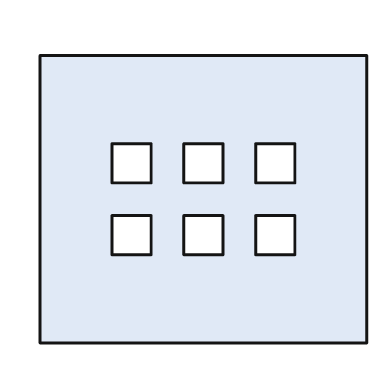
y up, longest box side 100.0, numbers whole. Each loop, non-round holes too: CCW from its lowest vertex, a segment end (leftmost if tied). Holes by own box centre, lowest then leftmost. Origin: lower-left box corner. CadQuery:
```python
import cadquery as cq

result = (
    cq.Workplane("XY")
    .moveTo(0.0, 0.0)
    .lineTo(100.0, 0.0)
    .lineTo(100.0, 88.0)
    .lineTo(0.0, 88.0)
    .close()
    .moveTo(22.0, 27.0)
    .lineTo(34.0, 27.0)
    .lineTo(34.0, 39.0)
    .lineTo(22.0, 39.0)
    .close()
    .moveTo(44.0, 27.0)
    .lineTo(56.0, 27.0)
    .lineTo(56.0, 39.0)
    .lineTo(44.0, 39.0)
    .close()
    .moveTo(66.0, 27.0)
    .lineTo(78.0, 27.0)
    .lineTo(78.0, 39.0)
    .lineTo(66.0, 39.0)
    .close()
    .moveTo(22.0, 49.0)
    .lineTo(34.0, 49.0)
    .lineTo(34.0, 61.0)
    .lineTo(22.0, 61.0)
    .close()
    .moveTo(44.0, 49.0)
    .lineTo(56.0, 49.0)
    .lineTo(56.0, 61.0)
    .lineTo(44.0, 61.0)
    .close()
    .moveTo(66.0, 49.0)
    .lineTo(78.0, 49.0)
    .lineTo(78.0, 61.0)
    .lineTo(66.0, 61.0)
    .close()
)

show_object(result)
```